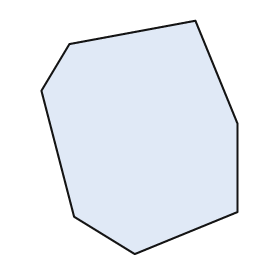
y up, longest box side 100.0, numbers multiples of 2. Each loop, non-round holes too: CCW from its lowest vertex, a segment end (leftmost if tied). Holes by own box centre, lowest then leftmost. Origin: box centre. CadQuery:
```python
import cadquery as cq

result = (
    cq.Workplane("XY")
    .moveTo(-2.0, -50.0)
    .lineTo(42.0, -32.0)
    .lineTo(42.0, 6.0)
    .lineTo(24.0, 50.0)
    .lineTo(-30.0, 40.0)
    .lineTo(-42.0, 20.0)
    .lineTo(-28.0, -34.0)
    .close()
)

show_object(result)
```